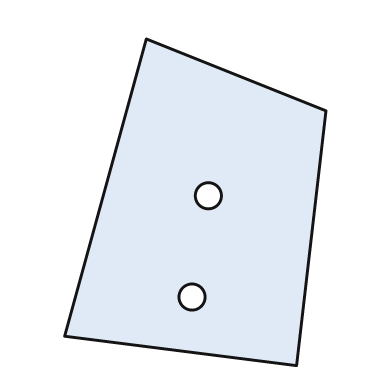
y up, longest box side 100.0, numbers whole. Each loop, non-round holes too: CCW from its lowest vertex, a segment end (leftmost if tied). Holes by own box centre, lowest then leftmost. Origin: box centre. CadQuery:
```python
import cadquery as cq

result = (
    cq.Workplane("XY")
    .moveTo(31.0, -50.0)
    .lineTo(40.0, 28.0)
    .lineTo(-15.0, 50.0)
    .lineTo(-40.0, -41.0)
    .close()
    .moveTo(-1.0, -29.0)
    .circle(4.0)
    .moveTo(4.0, 2.0)
    .circle(4.0)
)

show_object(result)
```